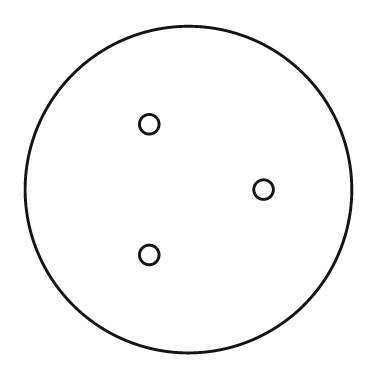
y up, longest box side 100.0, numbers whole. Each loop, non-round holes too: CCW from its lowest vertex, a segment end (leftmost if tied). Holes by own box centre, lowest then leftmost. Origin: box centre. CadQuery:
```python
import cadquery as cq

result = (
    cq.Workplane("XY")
    .moveTo(0.0, 0.0)
    .circle(50.0)
    .moveTo(-12.0, -20.0)
    .circle(3.0)
    .moveTo(23.0, 0.0)
    .circle(3.0)
    .moveTo(-12.0, 20.0)
    .circle(3.0)
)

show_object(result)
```